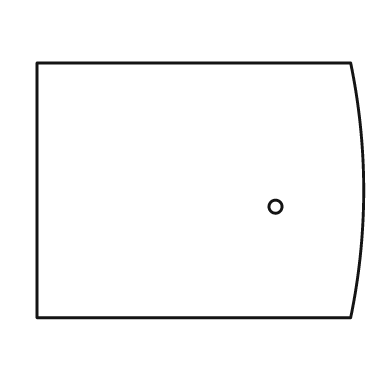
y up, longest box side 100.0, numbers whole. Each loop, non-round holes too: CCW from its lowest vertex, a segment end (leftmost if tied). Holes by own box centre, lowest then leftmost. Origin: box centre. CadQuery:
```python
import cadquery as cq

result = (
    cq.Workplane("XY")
    .moveTo(-50.0, -39.0)
    .lineTo(46.0, -39.0)
    .threePointArc((50.0, 0.0), (46.0, 39.0))
    .lineTo(-50.0, 39.0)
    .close()
    .moveTo(23.0, -5.0)
    .circle(2.0)
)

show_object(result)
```